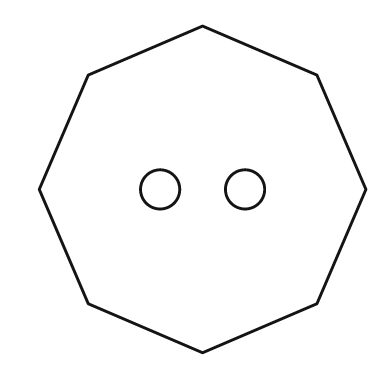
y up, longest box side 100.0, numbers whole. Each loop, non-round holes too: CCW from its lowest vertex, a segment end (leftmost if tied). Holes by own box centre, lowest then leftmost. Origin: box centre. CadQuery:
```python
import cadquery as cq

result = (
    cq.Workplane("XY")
    .moveTo(0.0, -50.0)
    .lineTo(35.0, -35.0)
    .lineTo(50.0, 0.0)
    .lineTo(35.0, 35.0)
    .lineTo(0.0, 50.0)
    .lineTo(-35.0, 35.0)
    .lineTo(-50.0, 0.0)
    .lineTo(-35.0, -35.0)
    .close()
    .moveTo(-13.0, 0.0)
    .circle(6.0)
    .moveTo(13.0, 0.0)
    .circle(6.0)
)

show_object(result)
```